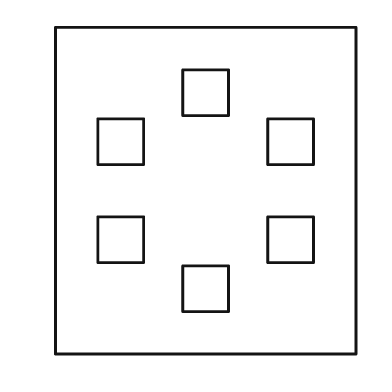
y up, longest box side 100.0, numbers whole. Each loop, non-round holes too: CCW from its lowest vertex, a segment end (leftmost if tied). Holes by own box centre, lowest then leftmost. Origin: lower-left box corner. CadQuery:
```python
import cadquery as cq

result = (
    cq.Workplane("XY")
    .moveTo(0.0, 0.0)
    .lineTo(92.0, 0.0)
    .lineTo(92.0, 100.0)
    .lineTo(0.0, 100.0)
    .close()
    .moveTo(39.0, 13.0)
    .lineTo(53.0, 13.0)
    .lineTo(53.0, 27.0)
    .lineTo(39.0, 27.0)
    .close()
    .moveTo(13.0, 28.0)
    .lineTo(27.0, 28.0)
    .lineTo(27.0, 42.0)
    .lineTo(13.0, 42.0)
    .close()
    .moveTo(65.0, 28.0)
    .lineTo(79.0, 28.0)
    .lineTo(79.0, 42.0)
    .lineTo(65.0, 42.0)
    .close()
    .moveTo(13.0, 58.0)
    .lineTo(27.0, 58.0)
    .lineTo(27.0, 72.0)
    .lineTo(13.0, 72.0)
    .close()
    .moveTo(65.0, 58.0)
    .lineTo(79.0, 58.0)
    .lineTo(79.0, 72.0)
    .lineTo(65.0, 72.0)
    .close()
    .moveTo(39.0, 73.0)
    .lineTo(53.0, 73.0)
    .lineTo(53.0, 87.0)
    .lineTo(39.0, 87.0)
    .close()
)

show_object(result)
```